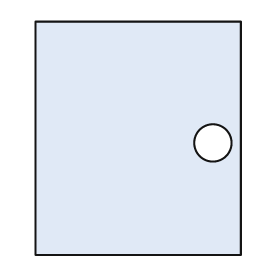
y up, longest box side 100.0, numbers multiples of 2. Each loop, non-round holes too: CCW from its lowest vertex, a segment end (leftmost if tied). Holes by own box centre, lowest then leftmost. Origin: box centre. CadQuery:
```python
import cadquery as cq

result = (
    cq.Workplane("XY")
    .moveTo(-44.0, -50.0)
    .lineTo(44.0, -50.0)
    .lineTo(44.0, 50.0)
    .lineTo(-44.0, 50.0)
    .close()
    .moveTo(32.0, -2.0)
    .circle(8.0)
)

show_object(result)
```